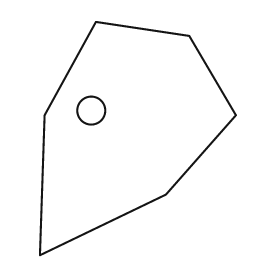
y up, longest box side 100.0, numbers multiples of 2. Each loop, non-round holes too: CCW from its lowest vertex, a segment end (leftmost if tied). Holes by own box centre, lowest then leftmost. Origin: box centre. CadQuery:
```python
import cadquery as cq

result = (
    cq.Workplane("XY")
    .moveTo(-42.0, -50.0)
    .lineTo(12.0, -24.0)
    .lineTo(42.0, 10.0)
    .lineTo(22.0, 44.0)
    .lineTo(-18.0, 50.0)
    .lineTo(-40.0, 10.0)
    .close()
    .moveTo(-20.0, 12.0)
    .circle(6.0)
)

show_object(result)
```